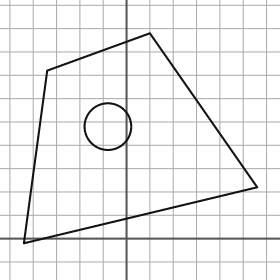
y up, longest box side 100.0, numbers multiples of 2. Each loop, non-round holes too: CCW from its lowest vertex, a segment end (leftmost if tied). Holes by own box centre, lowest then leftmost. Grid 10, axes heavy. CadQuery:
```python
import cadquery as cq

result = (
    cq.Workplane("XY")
    .moveTo(-44.0, -2.0)
    .lineTo(56.0, 22.0)
    .lineTo(10.0, 88.0)
    .lineTo(-34.0, 72.0)
    .close()
    .moveTo(-8.0, 48.0)
    .circle(10.0)
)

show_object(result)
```